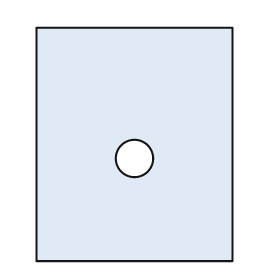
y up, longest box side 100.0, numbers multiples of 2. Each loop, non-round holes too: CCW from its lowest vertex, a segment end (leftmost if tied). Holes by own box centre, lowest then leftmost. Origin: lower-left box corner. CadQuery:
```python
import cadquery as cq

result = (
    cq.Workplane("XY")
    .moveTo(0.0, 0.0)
    .lineTo(84.0, 0.0)
    .lineTo(84.0, 100.0)
    .lineTo(0.0, 100.0)
    .close()
    .moveTo(42.0, 44.0)
    .circle(8.0)
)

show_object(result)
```